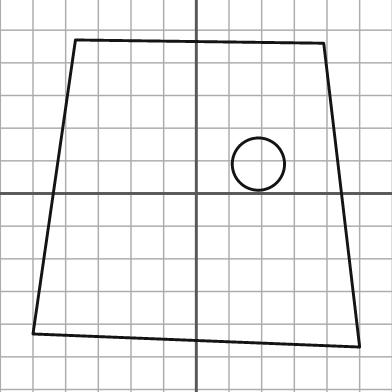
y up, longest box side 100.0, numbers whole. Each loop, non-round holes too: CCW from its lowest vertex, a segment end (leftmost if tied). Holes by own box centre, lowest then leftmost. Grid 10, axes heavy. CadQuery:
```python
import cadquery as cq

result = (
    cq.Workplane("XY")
    .moveTo(50.0, -47.0)
    .lineTo(39.0, 46.0)
    .lineTo(-37.0, 47.0)
    .lineTo(-50.0, -43.0)
    .close()
    .moveTo(19.0, 9.0)
    .circle(8.0)
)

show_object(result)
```